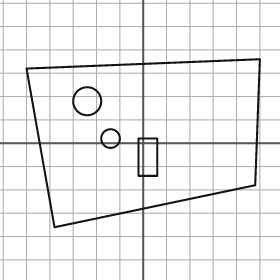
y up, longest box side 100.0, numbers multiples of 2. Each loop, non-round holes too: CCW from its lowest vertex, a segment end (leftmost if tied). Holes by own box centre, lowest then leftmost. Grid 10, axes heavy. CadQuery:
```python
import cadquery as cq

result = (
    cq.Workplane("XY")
    .moveTo(-38.0, -36.0)
    .lineTo(48.0, -18.0)
    .lineTo(50.0, 36.0)
    .lineTo(-50.0, 32.0)
    .close()
    .moveTo(-2.0, -14.0)
    .lineTo(6.0, -14.0)
    .lineTo(6.0, 2.0)
    .lineTo(-2.0, 2.0)
    .close()
    .moveTo(-14.0, 2.0)
    .circle(4.0)
    .moveTo(-24.0, 18.0)
    .circle(6.0)
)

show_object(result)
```